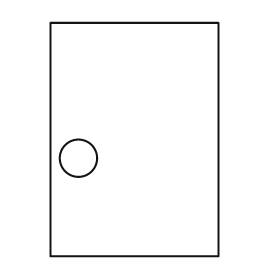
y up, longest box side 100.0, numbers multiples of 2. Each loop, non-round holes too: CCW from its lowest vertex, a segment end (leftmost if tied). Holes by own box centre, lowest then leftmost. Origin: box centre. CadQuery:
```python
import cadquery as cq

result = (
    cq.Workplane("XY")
    .moveTo(-36.0, -50.0)
    .lineTo(36.0, -50.0)
    .lineTo(36.0, 50.0)
    .lineTo(-36.0, 50.0)
    .close()
    .moveTo(-24.0, -8.0)
    .circle(8.0)
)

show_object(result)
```